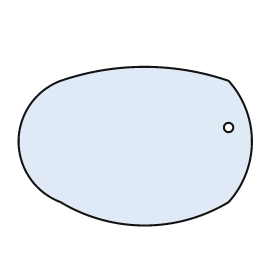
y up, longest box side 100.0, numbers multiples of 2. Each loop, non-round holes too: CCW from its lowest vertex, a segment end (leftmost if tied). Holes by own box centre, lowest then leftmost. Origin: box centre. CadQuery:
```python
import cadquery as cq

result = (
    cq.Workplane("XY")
    .moveTo(-32.0, -24.0)
    .threePointArc((4.0, -34.0), (40.0, -24.0))
    .threePointArc((50.0, 2.0), (40.0, 28.0))
    .threePointArc((4.0, 34.0), (-32.0, 28.0))
    .threePointArc((-50.0, 2.0), (-32.0, -24.0))
    .close()
    .moveTo(40.0, 8.0)
    .circle(2.0)
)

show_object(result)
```